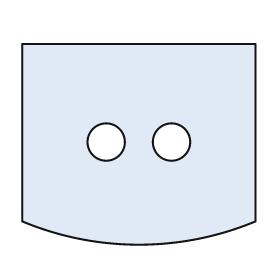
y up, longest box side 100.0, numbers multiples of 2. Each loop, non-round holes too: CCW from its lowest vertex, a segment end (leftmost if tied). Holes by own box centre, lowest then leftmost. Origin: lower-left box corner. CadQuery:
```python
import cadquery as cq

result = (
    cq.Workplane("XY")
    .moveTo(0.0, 10.0)
    .threePointArc((50.0, 0.0), (100.0, 10.0))
    .lineTo(100.0, 86.0)
    .lineTo(0.0, 86.0)
    .close()
    .moveTo(36.0, 44.0)
    .circle(8.0)
    .moveTo(64.0, 44.0)
    .circle(8.0)
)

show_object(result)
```